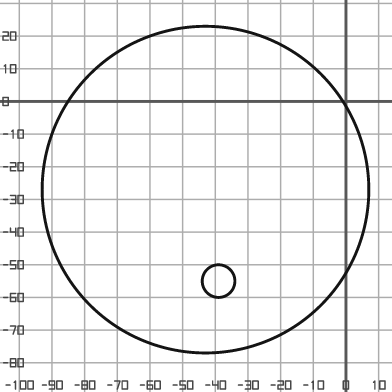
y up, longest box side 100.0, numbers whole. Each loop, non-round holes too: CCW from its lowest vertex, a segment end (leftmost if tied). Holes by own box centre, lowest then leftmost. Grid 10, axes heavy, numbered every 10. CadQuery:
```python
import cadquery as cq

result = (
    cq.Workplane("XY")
    .moveTo(-43.0, -27.0)
    .circle(50.0)
    .moveTo(-39.0, -55.0)
    .circle(5.0)
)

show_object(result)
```